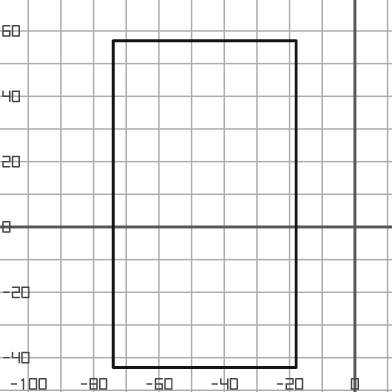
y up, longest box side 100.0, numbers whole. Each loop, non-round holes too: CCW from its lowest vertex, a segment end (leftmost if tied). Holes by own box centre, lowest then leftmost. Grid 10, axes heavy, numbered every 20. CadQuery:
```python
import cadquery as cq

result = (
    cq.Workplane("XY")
    .moveTo(-74.0, -43.0)
    .lineTo(-18.0, -43.0)
    .lineTo(-18.0, 57.0)
    .lineTo(-74.0, 57.0)
    .close()
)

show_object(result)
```